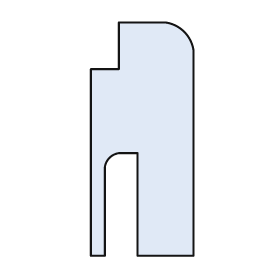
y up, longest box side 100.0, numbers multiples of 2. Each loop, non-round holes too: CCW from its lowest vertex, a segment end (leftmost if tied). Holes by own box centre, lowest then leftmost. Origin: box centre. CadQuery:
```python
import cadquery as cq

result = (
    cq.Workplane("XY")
    .moveTo(-22.0, -50.0)
    .lineTo(-16.0, -50.0)
    .lineTo(-16.0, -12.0)
    .threePointArc((-14.0, -8.0), (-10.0, -6.0))
    .lineTo(-2.0, -6.0)
    .lineTo(-2.0, -50.0)
    .lineTo(22.0, -50.0)
    .lineTo(22.0, 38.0)
    .threePointArc((18.0, 46.0), (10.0, 50.0))
    .lineTo(-10.0, 50.0)
    .lineTo(-10.0, 30.0)
    .lineTo(-22.0, 30.0)
    .close()
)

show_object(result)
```